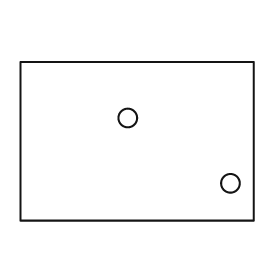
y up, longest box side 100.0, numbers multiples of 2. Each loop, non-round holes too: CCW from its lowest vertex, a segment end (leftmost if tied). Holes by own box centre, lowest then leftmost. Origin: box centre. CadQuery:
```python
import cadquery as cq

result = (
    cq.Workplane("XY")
    .moveTo(-50.0, -34.0)
    .lineTo(50.0, -34.0)
    .lineTo(50.0, 34.0)
    .lineTo(-50.0, 34.0)
    .close()
    .moveTo(40.0, -18.0)
    .circle(4.0)
    .moveTo(-4.0, 10.0)
    .circle(4.0)
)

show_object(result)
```